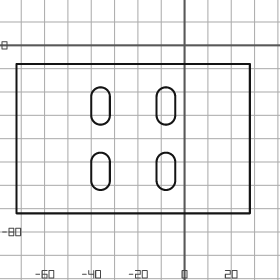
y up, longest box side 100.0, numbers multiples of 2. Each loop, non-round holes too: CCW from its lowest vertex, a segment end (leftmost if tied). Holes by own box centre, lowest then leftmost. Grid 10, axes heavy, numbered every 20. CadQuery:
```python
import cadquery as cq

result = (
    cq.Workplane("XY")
    .moveTo(-72.0, -72.0)
    .lineTo(28.0, -72.0)
    .lineTo(28.0, -8.0)
    .lineTo(-72.0, -8.0)
    .close()
    .moveTo(-40.0, -58.0)
    .threePointArc((-36.0, -62.0), (-32.0, -58.0))
    .lineTo(-32.0, -50.0)
    .threePointArc((-36.0, -46.0), (-40.0, -50.0))
    .close()
    .moveTo(-12.0, -58.0)
    .threePointArc((-8.0, -62.0), (-4.0, -58.0))
    .lineTo(-4.0, -50.0)
    .threePointArc((-8.0, -46.0), (-12.0, -50.0))
    .close()
    .moveTo(-40.0, -30.0)
    .threePointArc((-36.0, -34.0), (-32.0, -30.0))
    .lineTo(-32.0, -22.0)
    .threePointArc((-36.0, -18.0), (-40.0, -22.0))
    .close()
    .moveTo(-12.0, -30.0)
    .threePointArc((-8.0, -34.0), (-4.0, -30.0))
    .lineTo(-4.0, -22.0)
    .threePointArc((-8.0, -18.0), (-12.0, -22.0))
    .close()
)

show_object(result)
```